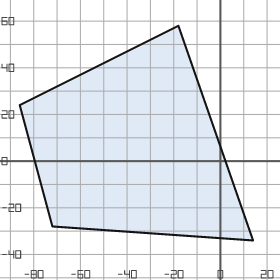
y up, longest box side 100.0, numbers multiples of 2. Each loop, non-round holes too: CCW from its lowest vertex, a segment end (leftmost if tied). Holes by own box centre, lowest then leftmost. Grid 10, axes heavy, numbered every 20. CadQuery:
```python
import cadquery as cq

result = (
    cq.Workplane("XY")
    .moveTo(14.0, -34.0)
    .lineTo(-18.0, 58.0)
    .lineTo(-86.0, 24.0)
    .lineTo(-72.0, -28.0)
    .close()
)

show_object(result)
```